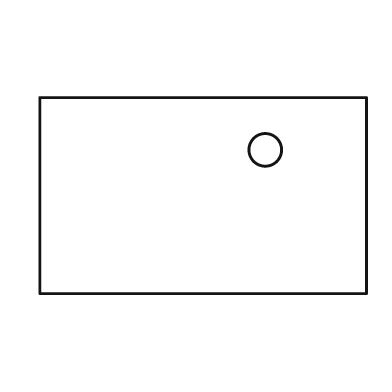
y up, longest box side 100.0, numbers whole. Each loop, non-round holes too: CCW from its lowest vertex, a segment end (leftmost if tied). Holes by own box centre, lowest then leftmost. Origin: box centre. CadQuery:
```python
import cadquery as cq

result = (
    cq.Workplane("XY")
    .moveTo(-50.0, -30.0)
    .lineTo(50.0, -30.0)
    .lineTo(50.0, 30.0)
    .lineTo(-50.0, 30.0)
    .close()
    .moveTo(19.0, 14.0)
    .circle(5.0)
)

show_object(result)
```